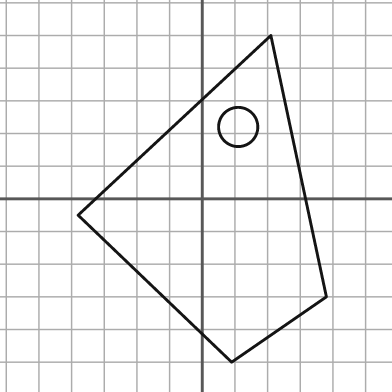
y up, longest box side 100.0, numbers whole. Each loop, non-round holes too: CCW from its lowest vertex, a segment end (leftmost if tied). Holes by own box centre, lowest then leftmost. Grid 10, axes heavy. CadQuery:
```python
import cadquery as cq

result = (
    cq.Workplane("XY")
    .moveTo(9.0, -50.0)
    .lineTo(38.0, -30.0)
    .lineTo(21.0, 50.0)
    .lineTo(-38.0, -5.0)
    .close()
    .moveTo(11.0, 22.0)
    .circle(6.0)
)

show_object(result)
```